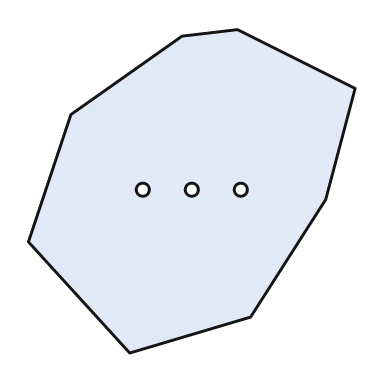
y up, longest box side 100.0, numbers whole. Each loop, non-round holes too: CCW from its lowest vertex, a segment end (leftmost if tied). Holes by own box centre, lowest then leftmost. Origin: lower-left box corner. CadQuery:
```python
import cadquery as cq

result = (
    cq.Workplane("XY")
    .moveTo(31.0, 0.0)
    .lineTo(68.0, 11.0)
    .lineTo(91.0, 47.0)
    .lineTo(100.0, 81.0)
    .lineTo(64.0, 99.0)
    .lineTo(47.0, 97.0)
    .lineTo(13.0, 73.0)
    .lineTo(0.0, 34.0)
    .close()
    .moveTo(35.0, 50.0)
    .circle(2.0)
    .moveTo(50.0, 50.0)
    .circle(2.0)
    .moveTo(65.0, 50.0)
    .circle(2.0)
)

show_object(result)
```